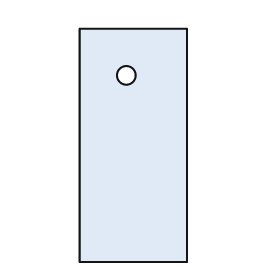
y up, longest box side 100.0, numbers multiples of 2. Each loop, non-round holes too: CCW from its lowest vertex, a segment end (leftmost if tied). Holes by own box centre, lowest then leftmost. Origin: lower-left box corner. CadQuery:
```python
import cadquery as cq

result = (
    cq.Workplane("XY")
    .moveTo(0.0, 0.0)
    .lineTo(46.0, 0.0)
    .lineTo(46.0, 100.0)
    .lineTo(0.0, 100.0)
    .close()
    .moveTo(20.0, 80.0)
    .circle(4.0)
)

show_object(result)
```